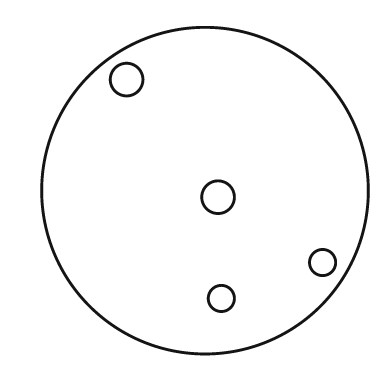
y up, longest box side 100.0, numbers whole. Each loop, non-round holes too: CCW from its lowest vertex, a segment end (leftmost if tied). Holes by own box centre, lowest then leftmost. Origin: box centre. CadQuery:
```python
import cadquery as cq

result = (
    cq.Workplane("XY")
    .moveTo(0.0, 0.0)
    .circle(50.0)
    .moveTo(5.0, -33.0)
    .circle(4.0)
    .moveTo(36.0, -22.0)
    .circle(4.0)
    .moveTo(4.0, -2.0)
    .circle(5.0)
    .moveTo(-24.0, 34.0)
    .circle(5.0)
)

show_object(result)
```